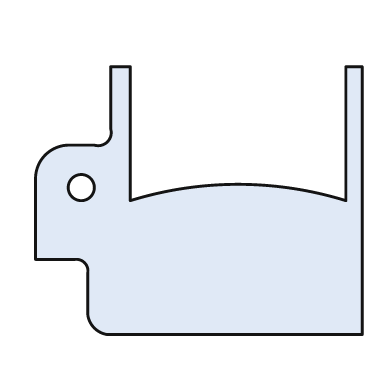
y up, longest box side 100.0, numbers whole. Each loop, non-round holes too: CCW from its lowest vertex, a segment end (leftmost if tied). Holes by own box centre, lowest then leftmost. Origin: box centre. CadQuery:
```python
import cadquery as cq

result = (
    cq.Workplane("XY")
    .moveTo(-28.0, -41.0)
    .lineTo(50.0, -41.0)
    .lineTo(50.0, 41.0)
    .lineTo(45.0, 41.0)
    .lineTo(45.0, 0.0)
    .threePointArc((12.0, 5.0), (-21.0, 0.0))
    .lineTo(-21.0, 41.0)
    .lineTo(-27.0, 41.0)
    .lineTo(-27.0, 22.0)
    .threePointArc((-28.0, 18.0), (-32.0, 17.0))
    .lineTo(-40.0, 17.0)
    .threePointArc((-47.0, 14.0), (-50.0, 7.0))
    .lineTo(-50.0, -18.0)
    .lineTo(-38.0, -18.0)
    .threePointArc((-35.0, -19.0), (-34.0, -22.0))
    .lineTo(-34.0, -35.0)
    .threePointArc((-32.0, -39.0), (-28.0, -41.0))
    .close()
    .moveTo(-36.0, 4.0)
    .circle(4.0)
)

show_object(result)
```